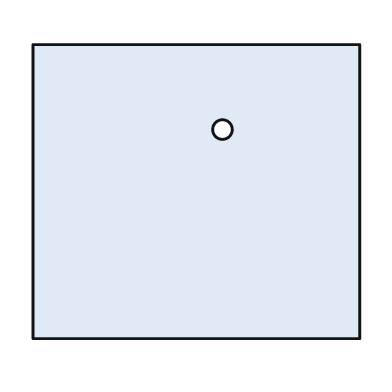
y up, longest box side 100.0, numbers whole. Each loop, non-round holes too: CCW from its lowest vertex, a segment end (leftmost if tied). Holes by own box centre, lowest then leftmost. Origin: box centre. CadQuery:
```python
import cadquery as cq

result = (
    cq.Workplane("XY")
    .moveTo(-50.0, -45.0)
    .lineTo(50.0, -45.0)
    .lineTo(50.0, 45.0)
    .lineTo(-50.0, 45.0)
    .close()
    .moveTo(8.0, 19.0)
    .circle(3.0)
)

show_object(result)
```